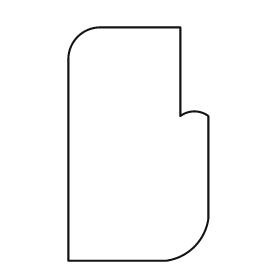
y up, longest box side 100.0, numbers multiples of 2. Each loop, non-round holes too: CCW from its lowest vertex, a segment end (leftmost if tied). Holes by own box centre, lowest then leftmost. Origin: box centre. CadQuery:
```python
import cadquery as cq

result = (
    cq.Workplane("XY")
    .moveTo(-30.0, -50.0)
    .lineTo(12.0, -50.0)
    .threePointArc((24.0, -44.0), (30.0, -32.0))
    .lineTo(30.0, 12.0)
    .threePointArc((24.0, 14.0), (18.0, 12.0))
    .lineTo(18.0, 50.0)
    .lineTo(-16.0, 50.0)
    .threePointArc((-26.0, 46.0), (-30.0, 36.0))
    .close()
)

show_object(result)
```